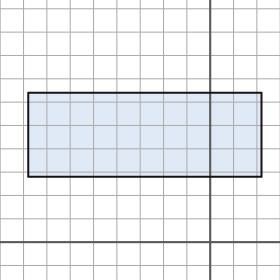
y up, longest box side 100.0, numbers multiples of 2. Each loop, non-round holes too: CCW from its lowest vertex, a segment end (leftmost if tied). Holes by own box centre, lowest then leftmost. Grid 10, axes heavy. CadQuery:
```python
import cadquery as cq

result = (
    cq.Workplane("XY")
    .moveTo(-78.0, 28.0)
    .lineTo(22.0, 28.0)
    .lineTo(22.0, 64.0)
    .lineTo(-78.0, 64.0)
    .close()
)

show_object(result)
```